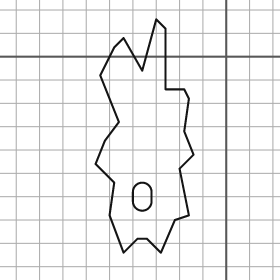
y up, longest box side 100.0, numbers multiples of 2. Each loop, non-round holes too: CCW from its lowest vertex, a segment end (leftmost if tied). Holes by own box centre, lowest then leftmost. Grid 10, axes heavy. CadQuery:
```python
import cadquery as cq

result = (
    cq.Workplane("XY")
    .moveTo(-44.0, -84.0)
    .lineTo(-38.0, -78.0)
    .lineTo(-34.0, -78.0)
    .lineTo(-28.0, -84.0)
    .lineTo(-22.0, -70.0)
    .lineTo(-16.0, -68.0)
    .lineTo(-20.0, -48.0)
    .lineTo(-14.0, -42.0)
    .lineTo(-18.0, -32.0)
    .lineTo(-16.0, -18.0)
    .lineTo(-18.0, -14.0)
    .lineTo(-26.0, -14.0)
    .lineTo(-26.0, 12.0)
    .lineTo(-30.0, 16.0)
    .lineTo(-36.0, -6.0)
    .lineTo(-44.0, 8.0)
    .lineTo(-48.0, 4.0)
    .lineTo(-54.0, -8.0)
    .lineTo(-46.0, -28.0)
    .lineTo(-52.0, -36.0)
    .lineTo(-56.0, -46.0)
    .lineTo(-48.0, -54.0)
    .lineTo(-50.0, -68.0)
    .close()
    .moveTo(-40.0, -62.0)
    .threePointArc((-36.0, -66.0), (-32.0, -62.0))
    .lineTo(-32.0, -58.0)
    .threePointArc((-36.0, -54.0), (-40.0, -58.0))
    .close()
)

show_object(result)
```